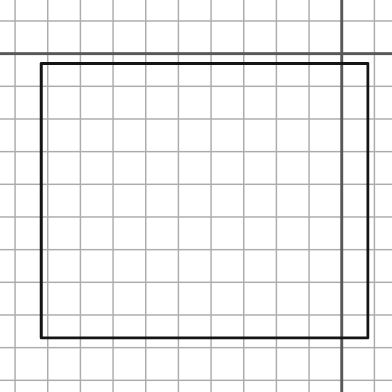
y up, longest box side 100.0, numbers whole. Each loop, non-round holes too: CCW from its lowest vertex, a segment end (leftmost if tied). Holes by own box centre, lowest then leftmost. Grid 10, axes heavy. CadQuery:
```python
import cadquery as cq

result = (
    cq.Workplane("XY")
    .moveTo(-92.0, -87.0)
    .lineTo(8.0, -87.0)
    .lineTo(8.0, -3.0)
    .lineTo(-92.0, -3.0)
    .close()
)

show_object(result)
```